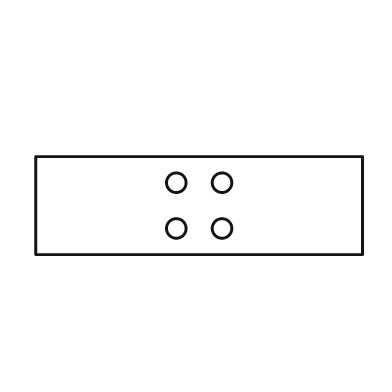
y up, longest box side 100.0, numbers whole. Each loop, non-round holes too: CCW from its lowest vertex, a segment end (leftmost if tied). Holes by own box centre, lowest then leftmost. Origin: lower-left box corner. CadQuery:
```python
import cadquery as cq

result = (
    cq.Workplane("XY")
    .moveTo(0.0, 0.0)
    .lineTo(100.0, 0.0)
    .lineTo(100.0, 30.0)
    .lineTo(0.0, 30.0)
    .close()
    .moveTo(43.0, 8.0)
    .circle(3.0)
    .moveTo(57.0, 8.0)
    .circle(3.0)
    .moveTo(43.0, 22.0)
    .circle(3.0)
    .moveTo(57.0, 22.0)
    .circle(3.0)
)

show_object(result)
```